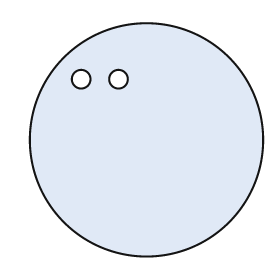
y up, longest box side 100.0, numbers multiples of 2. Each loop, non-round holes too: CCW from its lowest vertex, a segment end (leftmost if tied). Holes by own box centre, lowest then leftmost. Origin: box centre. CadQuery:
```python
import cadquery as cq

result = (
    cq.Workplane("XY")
    .moveTo(0.0, 0.0)
    .circle(50.0)
    .moveTo(-28.0, 26.0)
    .circle(4.0)
    .moveTo(-12.0, 26.0)
    .circle(4.0)
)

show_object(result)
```